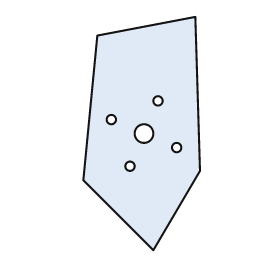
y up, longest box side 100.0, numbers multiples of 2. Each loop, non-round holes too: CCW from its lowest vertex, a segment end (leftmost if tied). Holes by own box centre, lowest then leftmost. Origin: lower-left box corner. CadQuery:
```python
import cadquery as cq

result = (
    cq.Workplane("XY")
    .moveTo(30.0, 0.0)
    .lineTo(50.0, 34.0)
    .lineTo(48.0, 100.0)
    .lineTo(6.0, 92.0)
    .lineTo(0.0, 30.0)
    .close()
    .moveTo(20.0, 36.0)
    .circle(2.0)
    .moveTo(40.0, 44.0)
    .circle(2.0)
    .moveTo(26.0, 50.0)
    .circle(4.0)
    .moveTo(12.0, 56.0)
    .circle(2.0)
    .moveTo(32.0, 64.0)
    .circle(2.0)
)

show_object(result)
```